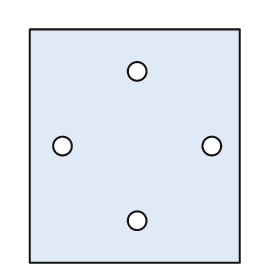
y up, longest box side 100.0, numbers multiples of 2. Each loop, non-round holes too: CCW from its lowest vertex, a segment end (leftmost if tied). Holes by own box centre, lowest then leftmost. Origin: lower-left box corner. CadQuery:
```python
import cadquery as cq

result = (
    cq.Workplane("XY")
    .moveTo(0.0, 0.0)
    .lineTo(90.0, 0.0)
    .lineTo(90.0, 100.0)
    .lineTo(0.0, 100.0)
    .close()
    .moveTo(46.0, 18.0)
    .circle(4.0)
    .moveTo(14.0, 50.0)
    .circle(4.0)
    .moveTo(78.0, 50.0)
    .circle(4.0)
    .moveTo(46.0, 82.0)
    .circle(4.0)
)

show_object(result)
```